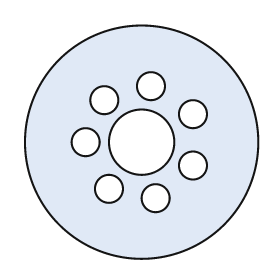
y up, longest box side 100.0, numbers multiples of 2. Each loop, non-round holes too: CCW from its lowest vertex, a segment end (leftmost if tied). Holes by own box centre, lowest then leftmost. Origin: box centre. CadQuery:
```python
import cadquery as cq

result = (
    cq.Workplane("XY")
    .moveTo(0.0, 0.0)
    .circle(50.0)
    .moveTo(6.0, -24.0)
    .circle(6.0)
    .moveTo(-14.0, -20.0)
    .circle(6.0)
    .moveTo(22.0, -10.0)
    .circle(6.0)
    .moveTo(-24.0, 0.0)
    .circle(6.0)
    .moveTo(0.0, 0.0)
    .circle(14.0)
    .moveTo(22.0, 12.0)
    .circle(6.0)
    .moveTo(-16.0, 18.0)
    .circle(6.0)
    .moveTo(4.0, 24.0)
    .circle(6.0)
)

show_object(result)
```